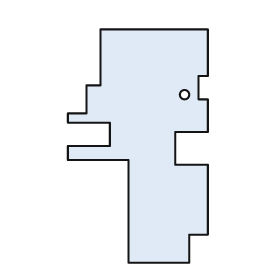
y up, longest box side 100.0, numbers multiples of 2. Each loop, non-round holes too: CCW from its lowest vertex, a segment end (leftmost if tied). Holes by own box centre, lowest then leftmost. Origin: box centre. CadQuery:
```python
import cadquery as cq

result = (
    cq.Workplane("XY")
    .moveTo(-4.0, -50.0)
    .lineTo(22.0, -50.0)
    .lineTo(22.0, -38.0)
    .lineTo(30.0, -38.0)
    .lineTo(30.0, -8.0)
    .lineTo(16.0, -8.0)
    .lineTo(16.0, 6.0)
    .lineTo(30.0, 6.0)
    .lineTo(30.0, 20.0)
    .lineTo(26.0, 20.0)
    .lineTo(26.0, 30.0)
    .lineTo(30.0, 30.0)
    .lineTo(30.0, 50.0)
    .lineTo(-16.0, 50.0)
    .lineTo(-16.0, 26.0)
    .lineTo(-22.0, 26.0)
    .lineTo(-22.0, 14.0)
    .lineTo(-30.0, 14.0)
    .lineTo(-30.0, 10.0)
    .lineTo(-12.0, 10.0)
    .lineTo(-12.0, 0.0)
    .lineTo(-30.0, 0.0)
    .lineTo(-30.0, -6.0)
    .lineTo(-4.0, -6.0)
    .close()
    .moveTo(20.0, 22.0)
    .circle(2.0)
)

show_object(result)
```